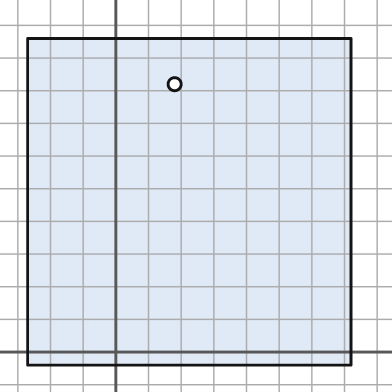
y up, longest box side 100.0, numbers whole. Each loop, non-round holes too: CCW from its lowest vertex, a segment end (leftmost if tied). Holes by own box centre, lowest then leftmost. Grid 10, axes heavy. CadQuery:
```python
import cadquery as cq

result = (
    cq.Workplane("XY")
    .moveTo(-27.0, -4.0)
    .lineTo(72.0, -4.0)
    .lineTo(72.0, 96.0)
    .lineTo(-27.0, 96.0)
    .close()
    .moveTo(18.0, 82.0)
    .circle(2.0)
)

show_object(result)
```